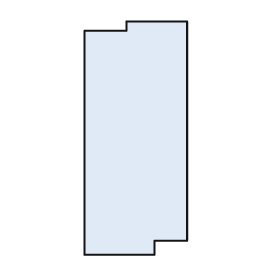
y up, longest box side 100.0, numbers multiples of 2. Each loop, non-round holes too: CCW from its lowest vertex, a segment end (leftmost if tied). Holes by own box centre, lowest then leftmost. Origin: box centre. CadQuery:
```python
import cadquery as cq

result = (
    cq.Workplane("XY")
    .moveTo(-22.0, -50.0)
    .lineTo(8.0, -50.0)
    .lineTo(8.0, -44.0)
    .lineTo(22.0, -44.0)
    .lineTo(22.0, 50.0)
    .lineTo(-4.0, 50.0)
    .lineTo(-4.0, 46.0)
    .lineTo(-22.0, 46.0)
    .close()
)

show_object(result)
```